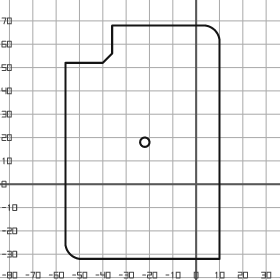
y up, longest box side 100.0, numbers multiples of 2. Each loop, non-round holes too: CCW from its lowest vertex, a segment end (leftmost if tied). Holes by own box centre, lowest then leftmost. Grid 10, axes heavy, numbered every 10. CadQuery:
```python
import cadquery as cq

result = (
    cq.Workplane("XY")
    .moveTo(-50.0, -32.0)
    .lineTo(10.0, -32.0)
    .lineTo(10.0, 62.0)
    .threePointArc((8.0, 66.0), (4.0, 68.0))
    .lineTo(-36.0, 68.0)
    .lineTo(-36.0, 56.0)
    .lineTo(-40.0, 52.0)
    .lineTo(-56.0, 52.0)
    .lineTo(-56.0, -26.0)
    .threePointArc((-54.0, -30.0), (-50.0, -32.0))
    .close()
    .moveTo(-22.0, 18.0)
    .circle(2.0)
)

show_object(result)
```